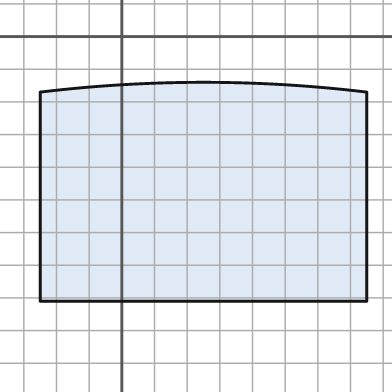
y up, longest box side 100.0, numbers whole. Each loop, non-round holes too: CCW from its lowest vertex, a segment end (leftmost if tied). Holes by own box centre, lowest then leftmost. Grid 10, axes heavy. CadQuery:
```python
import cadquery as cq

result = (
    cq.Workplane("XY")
    .moveTo(-25.0, -81.0)
    .lineTo(75.0, -81.0)
    .lineTo(75.0, -17.0)
    .threePointArc((25.0, -14.0), (-25.0, -17.0))
    .close()
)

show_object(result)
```